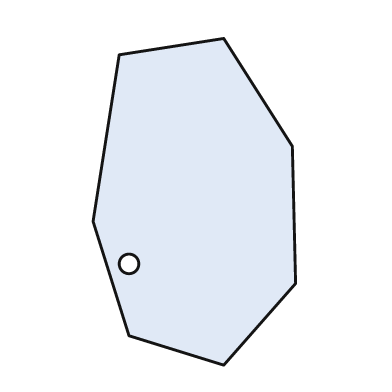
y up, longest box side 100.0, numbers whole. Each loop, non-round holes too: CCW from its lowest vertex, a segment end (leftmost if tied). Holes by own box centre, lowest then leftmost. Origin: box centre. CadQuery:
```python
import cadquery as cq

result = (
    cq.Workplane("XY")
    .moveTo(9.0, -50.0)
    .lineTo(31.0, -25.0)
    .lineTo(30.0, 17.0)
    .lineTo(9.0, 50.0)
    .lineTo(-23.0, 45.0)
    .lineTo(-31.0, -6.0)
    .lineTo(-20.0, -41.0)
    .close()
    .moveTo(-20.0, -19.0)
    .circle(3.0)
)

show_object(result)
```